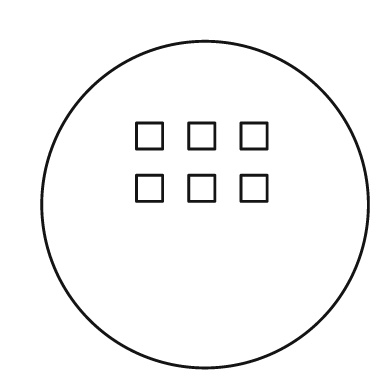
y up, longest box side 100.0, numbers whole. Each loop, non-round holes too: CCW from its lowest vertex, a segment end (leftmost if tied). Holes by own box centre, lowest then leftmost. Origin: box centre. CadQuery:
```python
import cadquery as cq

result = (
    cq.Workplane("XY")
    .moveTo(0.0, 0.0)
    .circle(50.0)
    .moveTo(-21.0, 1.0)
    .lineTo(-13.0, 1.0)
    .lineTo(-13.0, 9.0)
    .lineTo(-21.0, 9.0)
    .close()
    .moveTo(-5.0, 1.0)
    .lineTo(3.0, 1.0)
    .lineTo(3.0, 9.0)
    .lineTo(-5.0, 9.0)
    .close()
    .moveTo(11.0, 1.0)
    .lineTo(19.0, 1.0)
    .lineTo(19.0, 9.0)
    .lineTo(11.0, 9.0)
    .close()
    .moveTo(-21.0, 17.0)
    .lineTo(-13.0, 17.0)
    .lineTo(-13.0, 25.0)
    .lineTo(-21.0, 25.0)
    .close()
    .moveTo(-5.0, 17.0)
    .lineTo(3.0, 17.0)
    .lineTo(3.0, 25.0)
    .lineTo(-5.0, 25.0)
    .close()
    .moveTo(11.0, 17.0)
    .lineTo(19.0, 17.0)
    .lineTo(19.0, 25.0)
    .lineTo(11.0, 25.0)
    .close()
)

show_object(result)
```